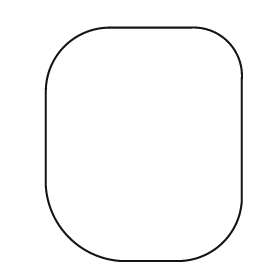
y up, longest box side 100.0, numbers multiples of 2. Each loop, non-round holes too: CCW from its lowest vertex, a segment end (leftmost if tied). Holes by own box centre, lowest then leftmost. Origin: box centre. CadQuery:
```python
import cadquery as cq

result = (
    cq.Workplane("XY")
    .moveTo(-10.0, -50.0)
    .lineTo(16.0, -50.0)
    .threePointArc((34.0, -42.0), (42.0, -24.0))
    .lineTo(42.0, 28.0)
    .threePointArc((36.0, 44.0), (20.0, 50.0))
    .lineTo(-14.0, 50.0)
    .threePointArc((-34.0, 42.0), (-42.0, 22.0))
    .lineTo(-42.0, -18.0)
    .threePointArc((-32.0, -40.0), (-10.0, -50.0))
    .close()
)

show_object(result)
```